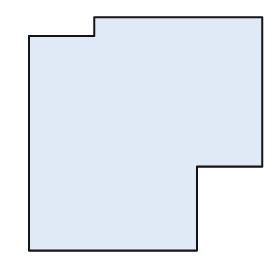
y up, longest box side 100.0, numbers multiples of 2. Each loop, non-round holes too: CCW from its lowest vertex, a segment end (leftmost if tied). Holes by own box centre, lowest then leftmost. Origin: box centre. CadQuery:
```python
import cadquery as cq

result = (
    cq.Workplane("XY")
    .moveTo(-50.0, -50.0)
    .lineTo(22.0, -50.0)
    .lineTo(22.0, -14.0)
    .lineTo(50.0, -14.0)
    .lineTo(50.0, 50.0)
    .lineTo(-22.0, 50.0)
    .lineTo(-22.0, 42.0)
    .lineTo(-50.0, 42.0)
    .close()
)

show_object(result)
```